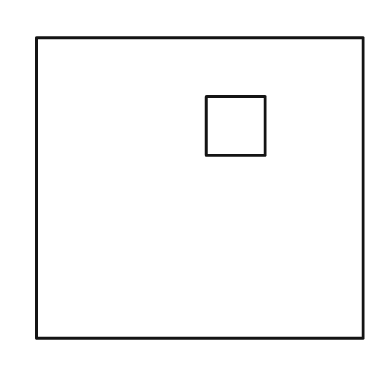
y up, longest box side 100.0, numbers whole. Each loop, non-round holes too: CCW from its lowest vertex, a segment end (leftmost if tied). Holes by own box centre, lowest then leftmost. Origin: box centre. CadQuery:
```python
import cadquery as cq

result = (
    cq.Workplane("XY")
    .moveTo(-50.0, -46.0)
    .lineTo(50.0, -46.0)
    .lineTo(50.0, 46.0)
    .lineTo(-50.0, 46.0)
    .close()
    .moveTo(2.0, 10.0)
    .lineTo(20.0, 10.0)
    .lineTo(20.0, 28.0)
    .lineTo(2.0, 28.0)
    .close()
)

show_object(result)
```